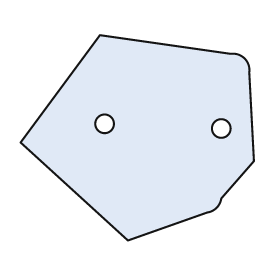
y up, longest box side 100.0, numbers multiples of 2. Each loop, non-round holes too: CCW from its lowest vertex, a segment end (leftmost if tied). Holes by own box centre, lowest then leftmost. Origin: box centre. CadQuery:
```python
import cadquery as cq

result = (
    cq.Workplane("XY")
    .moveTo(-4.0, -44.0)
    .lineTo(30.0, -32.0)
    .threePointArc((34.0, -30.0), (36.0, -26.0))
    .lineTo(50.0, -10.0)
    .lineTo(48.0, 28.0)
    .threePointArc((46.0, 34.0), (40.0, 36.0))
    .lineTo(-16.0, 44.0)
    .lineTo(-50.0, -2.0)
    .close()
    .moveTo(36.0, 4.0)
    .circle(4.0)
    .moveTo(-14.0, 6.0)
    .circle(4.0)
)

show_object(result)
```